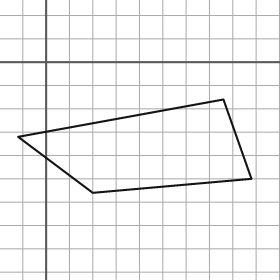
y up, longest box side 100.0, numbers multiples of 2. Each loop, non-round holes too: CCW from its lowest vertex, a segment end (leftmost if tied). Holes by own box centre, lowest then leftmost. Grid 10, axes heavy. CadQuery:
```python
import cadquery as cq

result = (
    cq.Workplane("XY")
    .moveTo(20.0, -56.0)
    .lineTo(88.0, -50.0)
    .lineTo(76.0, -16.0)
    .lineTo(-12.0, -32.0)
    .close()
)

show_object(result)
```